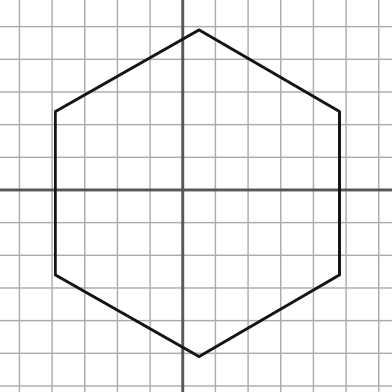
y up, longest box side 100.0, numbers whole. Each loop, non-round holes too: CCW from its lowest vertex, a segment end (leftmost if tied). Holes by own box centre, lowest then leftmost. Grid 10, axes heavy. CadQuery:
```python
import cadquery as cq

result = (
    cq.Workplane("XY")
    .moveTo(5.0, -51.0)
    .lineTo(48.0, -26.0)
    .lineTo(48.0, 24.0)
    .lineTo(5.0, 49.0)
    .lineTo(-39.0, 24.0)
    .lineTo(-39.0, -26.0)
    .close()
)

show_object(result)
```